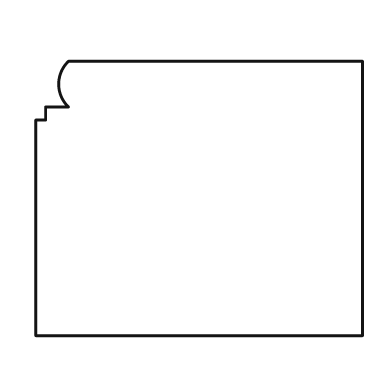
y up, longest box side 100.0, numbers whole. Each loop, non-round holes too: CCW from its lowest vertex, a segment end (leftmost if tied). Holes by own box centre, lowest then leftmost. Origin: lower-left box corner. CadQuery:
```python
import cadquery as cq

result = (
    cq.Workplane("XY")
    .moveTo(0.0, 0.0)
    .lineTo(100.0, 0.0)
    .lineTo(100.0, 84.0)
    .lineTo(10.0, 84.0)
    .threePointArc((7.0, 77.0), (10.0, 70.0))
    .lineTo(3.0, 70.0)
    .lineTo(3.0, 66.0)
    .lineTo(0.0, 66.0)
    .close()
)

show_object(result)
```